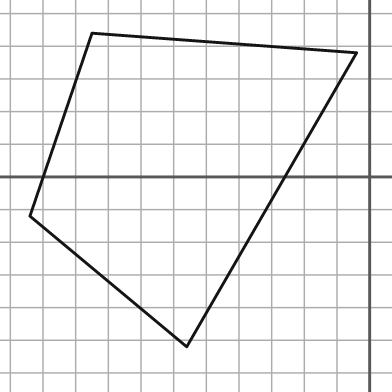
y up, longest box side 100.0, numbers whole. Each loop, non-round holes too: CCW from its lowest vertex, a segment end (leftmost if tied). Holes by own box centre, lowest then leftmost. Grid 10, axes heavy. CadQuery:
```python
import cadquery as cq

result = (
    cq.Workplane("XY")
    .moveTo(-56.0, -52.0)
    .lineTo(-4.0, 38.0)
    .lineTo(-85.0, 44.0)
    .lineTo(-104.0, -12.0)
    .close()
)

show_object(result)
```